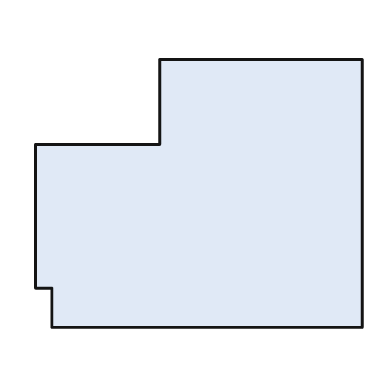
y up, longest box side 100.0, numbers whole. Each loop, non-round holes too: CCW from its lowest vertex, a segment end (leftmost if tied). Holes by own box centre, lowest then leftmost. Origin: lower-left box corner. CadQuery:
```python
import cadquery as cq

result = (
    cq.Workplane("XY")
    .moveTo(5.0, 0.0)
    .lineTo(100.0, 0.0)
    .lineTo(100.0, 82.0)
    .lineTo(38.0, 82.0)
    .lineTo(38.0, 56.0)
    .lineTo(0.0, 56.0)
    .lineTo(0.0, 12.0)
    .lineTo(5.0, 12.0)
    .close()
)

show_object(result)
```